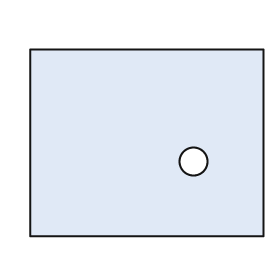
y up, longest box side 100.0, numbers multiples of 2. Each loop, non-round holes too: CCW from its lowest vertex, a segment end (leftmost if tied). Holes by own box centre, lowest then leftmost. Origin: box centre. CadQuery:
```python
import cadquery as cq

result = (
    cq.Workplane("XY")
    .moveTo(-50.0, -40.0)
    .lineTo(50.0, -40.0)
    .lineTo(50.0, 40.0)
    .lineTo(-50.0, 40.0)
    .close()
    .moveTo(20.0, -8.0)
    .circle(6.0)
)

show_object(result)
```